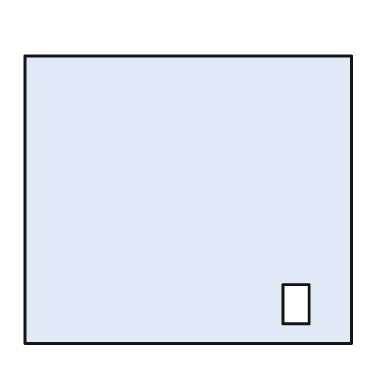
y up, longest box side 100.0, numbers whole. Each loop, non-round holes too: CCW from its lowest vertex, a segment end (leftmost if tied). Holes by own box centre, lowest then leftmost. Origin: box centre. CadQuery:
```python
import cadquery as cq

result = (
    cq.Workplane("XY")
    .moveTo(-50.0, -44.0)
    .lineTo(50.0, -44.0)
    .lineTo(50.0, 44.0)
    .lineTo(-50.0, 44.0)
    .close()
    .moveTo(29.0, -38.0)
    .lineTo(37.0, -38.0)
    .lineTo(37.0, -26.0)
    .lineTo(29.0, -26.0)
    .close()
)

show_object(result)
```